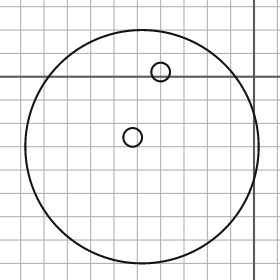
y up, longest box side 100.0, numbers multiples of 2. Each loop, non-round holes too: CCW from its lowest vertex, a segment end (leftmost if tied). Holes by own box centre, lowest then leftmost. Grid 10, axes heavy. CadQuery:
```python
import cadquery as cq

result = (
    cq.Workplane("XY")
    .moveTo(-48.0, -30.0)
    .circle(50.0)
    .moveTo(-52.0, -26.0)
    .circle(4.0)
    .moveTo(-40.0, 2.0)
    .circle(4.0)
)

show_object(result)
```